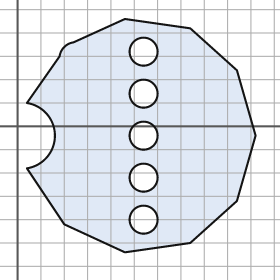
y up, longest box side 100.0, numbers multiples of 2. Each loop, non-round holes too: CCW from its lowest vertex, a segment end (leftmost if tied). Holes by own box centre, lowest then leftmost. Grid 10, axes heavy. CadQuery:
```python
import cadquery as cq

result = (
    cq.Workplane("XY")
    .moveTo(46.0, -54.0)
    .lineTo(74.0, -50.0)
    .lineTo(94.0, -32.0)
    .lineTo(102.0, -4.0)
    .lineTo(94.0, 24.0)
    .lineTo(74.0, 42.0)
    .lineTo(46.0, 46.0)
    .lineTo(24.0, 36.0)
    .threePointArc((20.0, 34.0), (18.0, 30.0))
    .lineTo(4.0, 10.0)
    .threePointArc((16.0, -4.0), (4.0, -18.0))
    .lineTo(20.0, -42.0)
    .close()
    .moveTo(54.0, -40.0)
    .circle(6.0)
    .moveTo(54.0, -22.0)
    .circle(6.0)
    .moveTo(54.0, -4.0)
    .circle(6.0)
    .moveTo(54.0, 14.0)
    .circle(6.0)
    .moveTo(54.0, 32.0)
    .circle(6.0)
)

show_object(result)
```